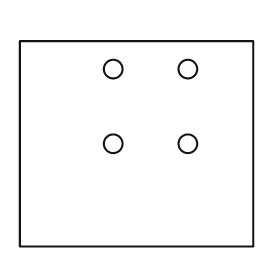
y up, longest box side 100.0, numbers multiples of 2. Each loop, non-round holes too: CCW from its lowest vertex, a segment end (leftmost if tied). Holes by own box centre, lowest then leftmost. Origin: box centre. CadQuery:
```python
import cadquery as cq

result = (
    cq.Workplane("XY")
    .moveTo(-50.0, -44.0)
    .lineTo(50.0, -44.0)
    .lineTo(50.0, 44.0)
    .lineTo(-50.0, 44.0)
    .close()
    .moveTo(-10.0, 0.0)
    .circle(4.0)
    .moveTo(22.0, 0.0)
    .circle(4.0)
    .moveTo(-10.0, 32.0)
    .circle(4.0)
    .moveTo(22.0, 32.0)
    .circle(4.0)
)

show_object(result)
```